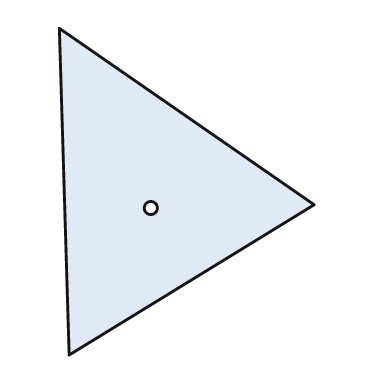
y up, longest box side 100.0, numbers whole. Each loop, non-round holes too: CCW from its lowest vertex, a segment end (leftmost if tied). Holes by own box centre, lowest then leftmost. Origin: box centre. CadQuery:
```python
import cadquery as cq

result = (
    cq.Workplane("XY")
    .moveTo(-36.0, -50.0)
    .lineTo(39.0, -4.0)
    .lineTo(-39.0, 50.0)
    .close()
    .moveTo(-11.0, -5.0)
    .circle(2.0)
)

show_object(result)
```